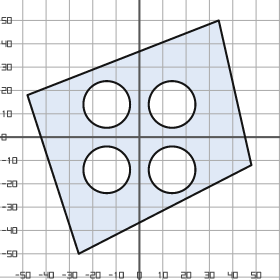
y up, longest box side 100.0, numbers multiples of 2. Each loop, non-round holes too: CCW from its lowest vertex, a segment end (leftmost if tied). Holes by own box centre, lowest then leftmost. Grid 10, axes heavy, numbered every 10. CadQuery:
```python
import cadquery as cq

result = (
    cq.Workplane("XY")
    .moveTo(-26.0, -50.0)
    .lineTo(48.0, -12.0)
    .lineTo(34.0, 50.0)
    .lineTo(-48.0, 18.0)
    .close()
    .moveTo(-14.0, -14.0)
    .circle(10.0)
    .moveTo(14.0, -14.0)
    .circle(10.0)
    .moveTo(-14.0, 14.0)
    .circle(10.0)
    .moveTo(14.0, 14.0)
    .circle(10.0)
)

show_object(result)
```